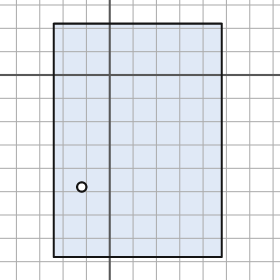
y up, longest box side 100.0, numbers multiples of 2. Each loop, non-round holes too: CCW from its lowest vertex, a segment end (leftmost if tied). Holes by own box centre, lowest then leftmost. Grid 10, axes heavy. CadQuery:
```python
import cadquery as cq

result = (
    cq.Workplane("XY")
    .moveTo(-24.0, -78.0)
    .lineTo(48.0, -78.0)
    .lineTo(48.0, 22.0)
    .lineTo(-24.0, 22.0)
    .close()
    .moveTo(-12.0, -48.0)
    .circle(2.0)
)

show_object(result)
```